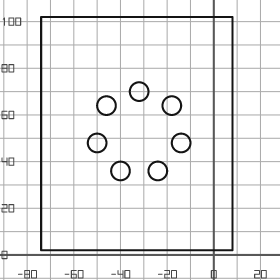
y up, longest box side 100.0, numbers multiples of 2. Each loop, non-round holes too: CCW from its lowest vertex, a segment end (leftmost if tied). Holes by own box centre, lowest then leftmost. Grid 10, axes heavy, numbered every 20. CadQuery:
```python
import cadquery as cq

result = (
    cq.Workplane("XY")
    .moveTo(-74.0, 2.0)
    .lineTo(8.0, 2.0)
    .lineTo(8.0, 102.0)
    .lineTo(-74.0, 102.0)
    .close()
    .moveTo(-40.0, 36.0)
    .circle(4.0)
    .moveTo(-24.0, 36.0)
    .circle(4.0)
    .moveTo(-50.0, 48.0)
    .circle(4.0)
    .moveTo(-14.0, 48.0)
    .circle(4.0)
    .moveTo(-46.0, 64.0)
    .circle(4.0)
    .moveTo(-18.0, 64.0)
    .circle(4.0)
    .moveTo(-32.0, 70.0)
    .circle(4.0)
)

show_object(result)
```